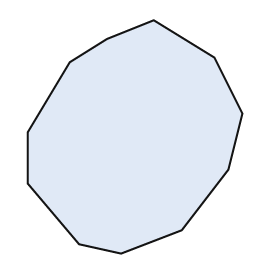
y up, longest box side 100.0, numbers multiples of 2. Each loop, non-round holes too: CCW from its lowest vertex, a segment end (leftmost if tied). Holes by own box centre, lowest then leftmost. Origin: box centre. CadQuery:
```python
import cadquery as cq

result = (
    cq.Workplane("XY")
    .moveTo(-6.0, -50.0)
    .lineTo(20.0, -40.0)
    .lineTo(40.0, -14.0)
    .lineTo(46.0, 10.0)
    .lineTo(34.0, 34.0)
    .lineTo(8.0, 50.0)
    .lineTo(-12.0, 42.0)
    .lineTo(-28.0, 32.0)
    .lineTo(-46.0, 2.0)
    .lineTo(-46.0, -20.0)
    .lineTo(-24.0, -46.0)
    .close()
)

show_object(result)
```